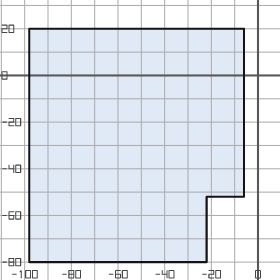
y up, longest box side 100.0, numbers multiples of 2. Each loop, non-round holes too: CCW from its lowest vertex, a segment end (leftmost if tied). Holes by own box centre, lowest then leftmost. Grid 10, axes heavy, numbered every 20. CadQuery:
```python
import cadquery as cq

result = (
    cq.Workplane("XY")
    .moveTo(-98.0, -80.0)
    .lineTo(-22.0, -80.0)
    .lineTo(-22.0, -52.0)
    .lineTo(-6.0, -52.0)
    .lineTo(-6.0, 20.0)
    .lineTo(-98.0, 20.0)
    .close()
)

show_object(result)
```